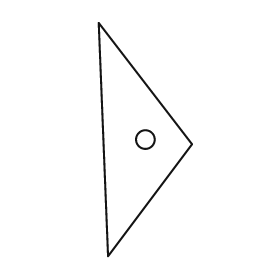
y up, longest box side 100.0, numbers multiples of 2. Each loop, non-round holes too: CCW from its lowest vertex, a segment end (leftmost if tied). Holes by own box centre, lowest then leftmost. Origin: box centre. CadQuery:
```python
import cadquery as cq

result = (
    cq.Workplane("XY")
    .moveTo(-16.0, -50.0)
    .lineTo(20.0, -2.0)
    .lineTo(-20.0, 50.0)
    .close()
    .moveTo(0.0, 0.0)
    .circle(4.0)
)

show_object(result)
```